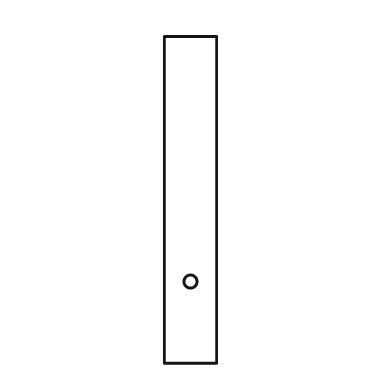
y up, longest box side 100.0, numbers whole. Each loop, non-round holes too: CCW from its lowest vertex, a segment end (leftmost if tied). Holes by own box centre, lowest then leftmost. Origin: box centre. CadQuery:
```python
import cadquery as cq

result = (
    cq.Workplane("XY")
    .moveTo(-8.0, -50.0)
    .lineTo(8.0, -50.0)
    .lineTo(8.0, 50.0)
    .lineTo(-8.0, 50.0)
    .close()
    .moveTo(0.0, -25.0)
    .circle(2.0)
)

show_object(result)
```